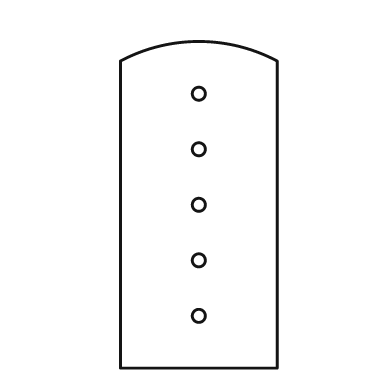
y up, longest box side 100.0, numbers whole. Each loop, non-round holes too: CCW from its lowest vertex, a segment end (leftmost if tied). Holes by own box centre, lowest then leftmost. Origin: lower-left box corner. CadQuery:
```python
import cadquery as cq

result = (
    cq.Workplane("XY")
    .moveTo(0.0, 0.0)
    .lineTo(48.0, 0.0)
    .lineTo(48.0, 94.0)
    .threePointArc((24.0, 100.0), (0.0, 94.0))
    .close()
    .moveTo(24.0, 16.0)
    .circle(2.0)
    .moveTo(24.0, 33.0)
    .circle(2.0)
    .moveTo(24.0, 50.0)
    .circle(2.0)
    .moveTo(24.0, 67.0)
    .circle(2.0)
    .moveTo(24.0, 84.0)
    .circle(2.0)
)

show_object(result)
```